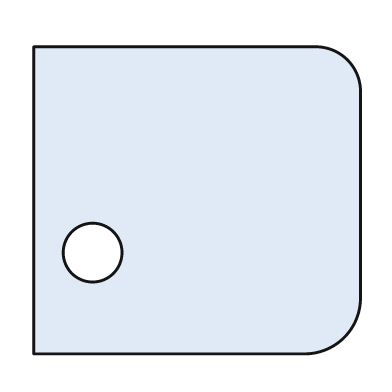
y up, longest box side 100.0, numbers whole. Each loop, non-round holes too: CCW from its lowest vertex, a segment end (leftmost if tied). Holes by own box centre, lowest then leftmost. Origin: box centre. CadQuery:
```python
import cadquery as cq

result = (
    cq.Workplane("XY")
    .moveTo(-50.0, -47.0)
    .lineTo(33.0, -47.0)
    .threePointArc((45.0, -42.0), (50.0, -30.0))
    .lineTo(50.0, 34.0)
    .threePointArc((46.0, 43.0), (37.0, 47.0))
    .lineTo(-50.0, 47.0)
    .close()
    .moveTo(-32.0, -16.0)
    .circle(9.0)
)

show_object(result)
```